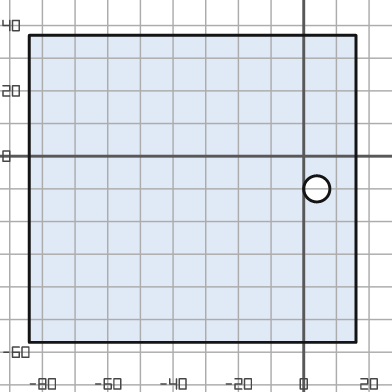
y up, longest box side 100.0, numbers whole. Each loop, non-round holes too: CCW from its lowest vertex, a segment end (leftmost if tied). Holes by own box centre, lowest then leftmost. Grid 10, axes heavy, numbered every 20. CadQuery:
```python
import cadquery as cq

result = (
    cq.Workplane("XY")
    .moveTo(-84.0, -57.0)
    .lineTo(16.0, -57.0)
    .lineTo(16.0, 37.0)
    .lineTo(-84.0, 37.0)
    .close()
    .moveTo(4.0, -10.0)
    .circle(4.0)
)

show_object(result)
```